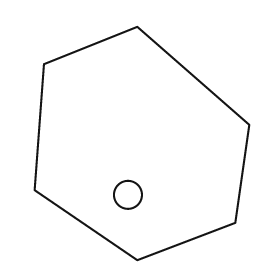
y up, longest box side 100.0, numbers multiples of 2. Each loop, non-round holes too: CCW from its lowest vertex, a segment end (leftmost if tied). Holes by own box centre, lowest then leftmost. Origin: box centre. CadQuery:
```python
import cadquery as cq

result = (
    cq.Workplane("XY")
    .moveTo(-2.0, -50.0)
    .lineTo(40.0, -34.0)
    .lineTo(46.0, 8.0)
    .lineTo(-2.0, 50.0)
    .lineTo(-42.0, 34.0)
    .lineTo(-46.0, -20.0)
    .close()
    .moveTo(-6.0, -22.0)
    .circle(6.0)
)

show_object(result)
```